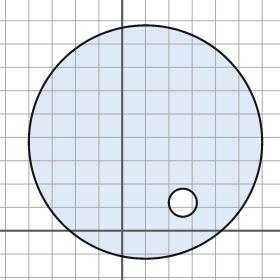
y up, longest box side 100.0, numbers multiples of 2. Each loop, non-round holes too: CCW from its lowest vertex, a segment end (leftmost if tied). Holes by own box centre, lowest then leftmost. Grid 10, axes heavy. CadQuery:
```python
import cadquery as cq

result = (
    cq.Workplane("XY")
    .moveTo(10.0, 38.0)
    .circle(50.0)
    .moveTo(26.0, 12.0)
    .circle(6.0)
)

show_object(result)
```